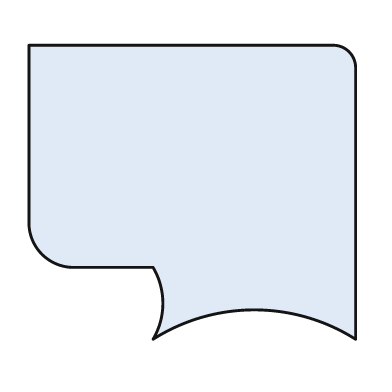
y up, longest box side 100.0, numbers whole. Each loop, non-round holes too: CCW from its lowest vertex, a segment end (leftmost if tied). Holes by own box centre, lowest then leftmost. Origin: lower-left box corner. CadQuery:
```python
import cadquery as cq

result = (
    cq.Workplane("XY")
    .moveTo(38.0, 0.0)
    .threePointArc((69.0, 9.0), (100.0, 0.0))
    .lineTo(100.0, 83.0)
    .threePointArc((98.0, 88.0), (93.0, 90.0))
    .lineTo(0.0, 90.0)
    .lineTo(0.0, 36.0)
    .threePointArc((4.0, 26.0), (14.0, 22.0))
    .lineTo(38.0, 22.0)
    .threePointArc((41.0, 11.0), (38.0, 0.0))
    .close()
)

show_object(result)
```